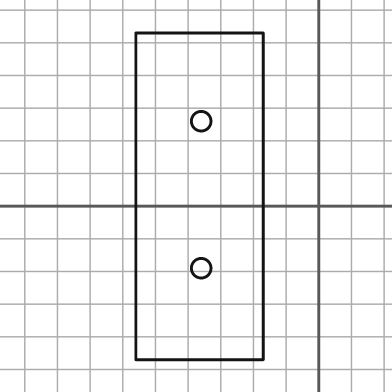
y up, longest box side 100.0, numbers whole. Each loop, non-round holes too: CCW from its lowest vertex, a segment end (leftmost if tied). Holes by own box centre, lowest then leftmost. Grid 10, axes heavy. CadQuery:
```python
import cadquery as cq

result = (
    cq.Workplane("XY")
    .moveTo(-56.0, -47.0)
    .lineTo(-17.0, -47.0)
    .lineTo(-17.0, 53.0)
    .lineTo(-56.0, 53.0)
    .close()
    .moveTo(-36.0, -19.0)
    .circle(3.0)
    .moveTo(-36.0, 26.0)
    .circle(3.0)
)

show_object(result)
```